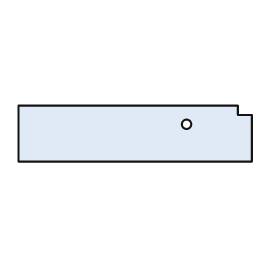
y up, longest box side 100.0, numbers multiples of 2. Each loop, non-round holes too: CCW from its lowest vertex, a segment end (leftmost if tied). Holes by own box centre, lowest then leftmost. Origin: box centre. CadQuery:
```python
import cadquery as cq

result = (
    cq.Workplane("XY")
    .moveTo(-50.0, -12.0)
    .lineTo(50.0, -12.0)
    .lineTo(50.0, 8.0)
    .lineTo(44.0, 8.0)
    .lineTo(44.0, 12.0)
    .lineTo(-50.0, 12.0)
    .close()
    .moveTo(22.0, 4.0)
    .circle(2.0)
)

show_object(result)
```